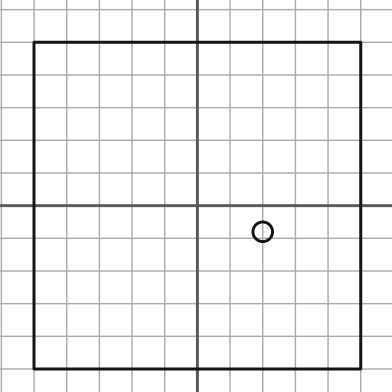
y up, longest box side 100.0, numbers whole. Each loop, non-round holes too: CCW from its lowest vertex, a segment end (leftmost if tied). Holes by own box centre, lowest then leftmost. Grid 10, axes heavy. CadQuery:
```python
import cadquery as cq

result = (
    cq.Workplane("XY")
    .moveTo(-50.0, -50.0)
    .lineTo(50.0, -50.0)
    .lineTo(50.0, 50.0)
    .lineTo(-50.0, 50.0)
    .close()
    .moveTo(20.0, -8.0)
    .circle(3.0)
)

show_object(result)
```